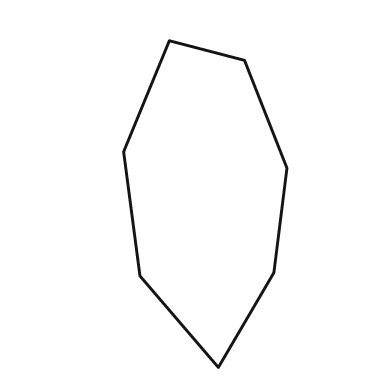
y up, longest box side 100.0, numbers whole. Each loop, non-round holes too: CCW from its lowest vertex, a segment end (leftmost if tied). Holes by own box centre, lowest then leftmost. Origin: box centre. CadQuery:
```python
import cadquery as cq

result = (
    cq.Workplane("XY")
    .moveTo(4.0, -50.0)
    .lineTo(21.0, -21.0)
    .lineTo(25.0, 11.0)
    .lineTo(12.0, 44.0)
    .lineTo(-11.0, 50.0)
    .lineTo(-25.0, 16.0)
    .lineTo(-20.0, -22.0)
    .close()
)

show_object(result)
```